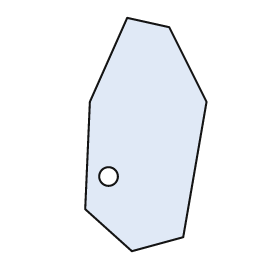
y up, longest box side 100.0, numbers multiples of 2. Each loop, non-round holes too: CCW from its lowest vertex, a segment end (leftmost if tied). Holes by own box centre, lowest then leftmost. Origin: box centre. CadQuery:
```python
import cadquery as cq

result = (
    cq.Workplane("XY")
    .moveTo(-6.0, -50.0)
    .lineTo(16.0, -44.0)
    .lineTo(26.0, 14.0)
    .lineTo(10.0, 46.0)
    .lineTo(-8.0, 50.0)
    .lineTo(-24.0, 14.0)
    .lineTo(-26.0, -32.0)
    .close()
    .moveTo(-16.0, -18.0)
    .circle(4.0)
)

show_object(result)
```